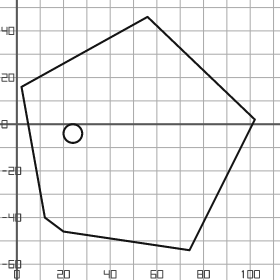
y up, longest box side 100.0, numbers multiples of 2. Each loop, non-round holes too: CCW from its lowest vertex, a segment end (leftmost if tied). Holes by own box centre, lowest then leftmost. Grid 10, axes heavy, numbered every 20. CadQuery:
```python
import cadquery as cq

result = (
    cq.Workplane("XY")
    .moveTo(74.0, -54.0)
    .lineTo(102.0, 2.0)
    .lineTo(56.0, 46.0)
    .lineTo(2.0, 16.0)
    .lineTo(12.0, -40.0)
    .lineTo(20.0, -46.0)
    .close()
    .moveTo(24.0, -4.0)
    .circle(4.0)
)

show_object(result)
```